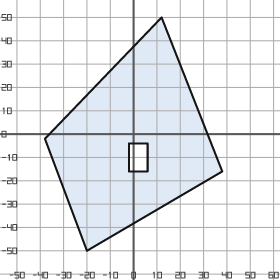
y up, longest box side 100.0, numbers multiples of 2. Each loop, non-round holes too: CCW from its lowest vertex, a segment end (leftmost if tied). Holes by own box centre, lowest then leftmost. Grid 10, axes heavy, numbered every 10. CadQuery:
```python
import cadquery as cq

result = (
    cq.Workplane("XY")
    .moveTo(-20.0, -50.0)
    .lineTo(38.0, -16.0)
    .lineTo(12.0, 50.0)
    .lineTo(-38.0, -2.0)
    .close()
    .moveTo(-2.0, -16.0)
    .lineTo(6.0, -16.0)
    .lineTo(6.0, -4.0)
    .lineTo(-2.0, -4.0)
    .close()
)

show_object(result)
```